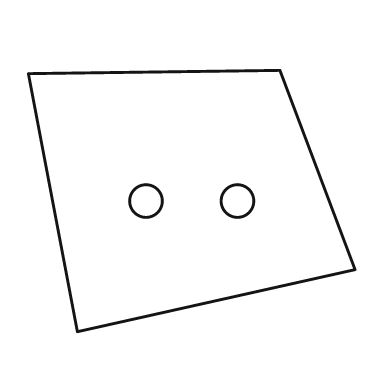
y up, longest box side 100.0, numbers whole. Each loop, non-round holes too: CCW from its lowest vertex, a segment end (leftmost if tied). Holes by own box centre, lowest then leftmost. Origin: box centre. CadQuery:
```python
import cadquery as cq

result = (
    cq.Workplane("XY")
    .moveTo(-35.0, -40.0)
    .lineTo(50.0, -21.0)
    .lineTo(27.0, 40.0)
    .lineTo(-50.0, 39.0)
    .close()
    .moveTo(-14.0, 0.0)
    .circle(5.0)
    .moveTo(14.0, 0.0)
    .circle(5.0)
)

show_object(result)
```